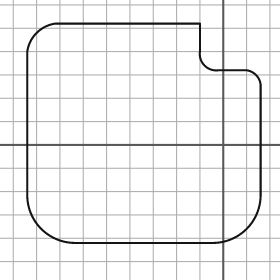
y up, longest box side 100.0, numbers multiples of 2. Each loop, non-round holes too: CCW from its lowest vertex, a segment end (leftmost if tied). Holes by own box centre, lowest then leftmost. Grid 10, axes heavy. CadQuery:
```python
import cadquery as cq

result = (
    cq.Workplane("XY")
    .moveTo(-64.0, -42.0)
    .lineTo(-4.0, -42.0)
    .threePointArc((10.0, -36.0), (16.0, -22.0))
    .lineTo(16.0, 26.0)
    .threePointArc((14.0, 30.0), (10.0, 32.0))
    .lineTo(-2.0, 32.0)
    .threePointArc((-8.0, 34.0), (-10.0, 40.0))
    .lineTo(-10.0, 52.0)
    .lineTo(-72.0, 52.0)
    .threePointArc((-80.0, 48.0), (-84.0, 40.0))
    .lineTo(-84.0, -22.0)
    .threePointArc((-78.0, -36.0), (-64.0, -42.0))
    .close()
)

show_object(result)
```